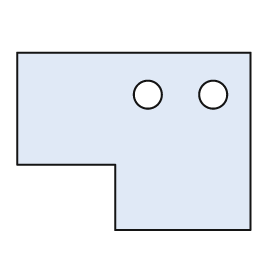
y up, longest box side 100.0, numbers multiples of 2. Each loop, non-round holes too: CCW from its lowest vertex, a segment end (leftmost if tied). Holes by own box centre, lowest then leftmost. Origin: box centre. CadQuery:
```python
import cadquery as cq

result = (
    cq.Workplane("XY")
    .moveTo(-8.0, -38.0)
    .lineTo(50.0, -38.0)
    .lineTo(50.0, 38.0)
    .lineTo(-50.0, 38.0)
    .lineTo(-50.0, -10.0)
    .lineTo(-8.0, -10.0)
    .close()
    .moveTo(6.0, 20.0)
    .circle(6.0)
    .moveTo(34.0, 20.0)
    .circle(6.0)
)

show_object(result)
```